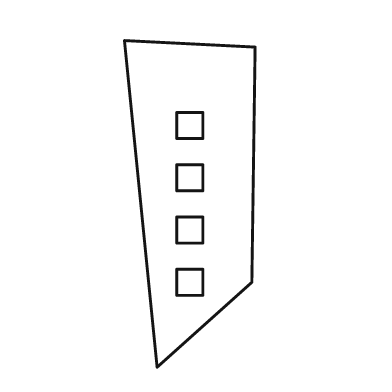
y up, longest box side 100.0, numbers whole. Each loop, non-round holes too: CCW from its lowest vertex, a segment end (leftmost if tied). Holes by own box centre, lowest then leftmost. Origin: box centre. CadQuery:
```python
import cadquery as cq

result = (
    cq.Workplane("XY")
    .moveTo(-10.0, -50.0)
    .lineTo(19.0, -24.0)
    .lineTo(20.0, 48.0)
    .lineTo(-20.0, 50.0)
    .close()
    .moveTo(-4.0, -28.0)
    .lineTo(4.0, -28.0)
    .lineTo(4.0, -20.0)
    .lineTo(-4.0, -20.0)
    .close()
    .moveTo(-4.0, -12.0)
    .lineTo(4.0, -12.0)
    .lineTo(4.0, -4.0)
    .lineTo(-4.0, -4.0)
    .close()
    .moveTo(-4.0, 4.0)
    .lineTo(4.0, 4.0)
    .lineTo(4.0, 12.0)
    .lineTo(-4.0, 12.0)
    .close()
    .moveTo(-4.0, 20.0)
    .lineTo(4.0, 20.0)
    .lineTo(4.0, 28.0)
    .lineTo(-4.0, 28.0)
    .close()
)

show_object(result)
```